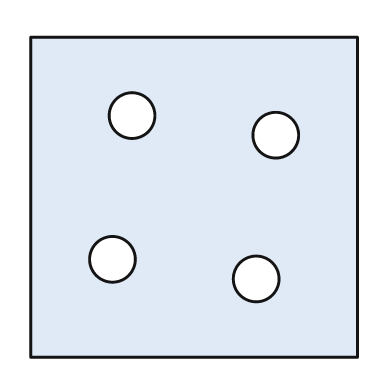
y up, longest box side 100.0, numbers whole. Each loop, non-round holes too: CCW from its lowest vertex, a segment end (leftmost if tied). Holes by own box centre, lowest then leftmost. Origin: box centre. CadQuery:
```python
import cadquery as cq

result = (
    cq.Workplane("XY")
    .moveTo(-50.0, -49.0)
    .lineTo(50.0, -49.0)
    .lineTo(50.0, 49.0)
    .lineTo(-50.0, 49.0)
    .close()
    .moveTo(19.0, -25.0)
    .circle(7.0)
    .moveTo(-25.0, -19.0)
    .circle(7.0)
    .moveTo(25.0, 19.0)
    .circle(7.0)
    .moveTo(-19.0, 25.0)
    .circle(7.0)
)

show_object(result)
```